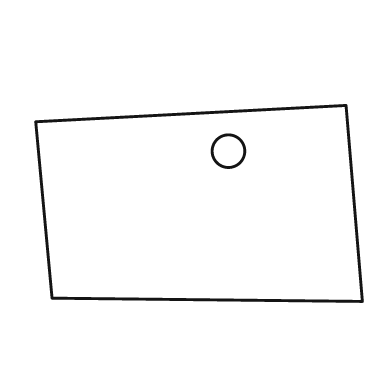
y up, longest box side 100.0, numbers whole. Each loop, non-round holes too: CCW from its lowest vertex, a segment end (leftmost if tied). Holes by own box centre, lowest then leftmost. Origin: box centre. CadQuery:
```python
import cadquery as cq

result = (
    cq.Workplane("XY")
    .moveTo(50.0, -30.0)
    .lineTo(45.0, 30.0)
    .lineTo(-50.0, 25.0)
    .lineTo(-45.0, -29.0)
    .close()
    .moveTo(9.0, 16.0)
    .circle(5.0)
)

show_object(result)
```